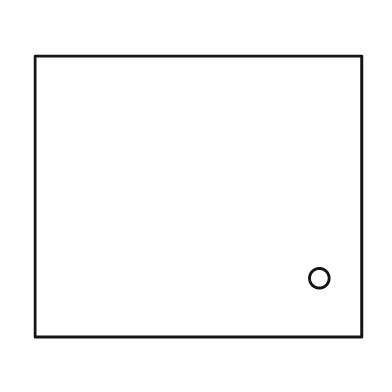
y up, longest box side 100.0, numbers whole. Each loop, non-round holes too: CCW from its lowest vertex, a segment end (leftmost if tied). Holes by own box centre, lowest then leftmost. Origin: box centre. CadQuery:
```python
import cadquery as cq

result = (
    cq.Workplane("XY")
    .moveTo(-50.0, -43.0)
    .lineTo(50.0, -43.0)
    .lineTo(50.0, 43.0)
    .lineTo(-50.0, 43.0)
    .close()
    .moveTo(37.0, -25.0)
    .circle(3.0)
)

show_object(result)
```